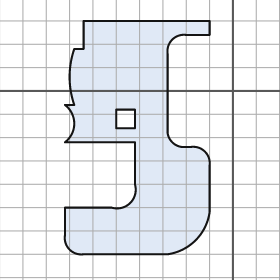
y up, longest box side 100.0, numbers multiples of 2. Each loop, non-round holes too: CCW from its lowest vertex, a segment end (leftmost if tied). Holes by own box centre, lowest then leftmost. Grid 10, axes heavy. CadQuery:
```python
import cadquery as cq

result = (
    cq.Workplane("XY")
    .moveTo(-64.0, -70.0)
    .lineTo(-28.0, -70.0)
    .threePointArc((-16.0, -64.0), (-10.0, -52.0))
    .lineTo(-10.0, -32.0)
    .threePointArc((-12.0, -26.0), (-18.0, -24.0))
    .lineTo(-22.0, -24.0)
    .threePointArc((-26.0, -22.0), (-28.0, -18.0))
    .lineTo(-28.0, 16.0)
    .threePointArc((-26.0, 22.0), (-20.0, 24.0))
    .lineTo(-10.0, 24.0)
    .lineTo(-10.0, 30.0)
    .lineTo(-64.0, 30.0)
    .lineTo(-64.0, 18.0)
    .lineTo(-68.0, 18.0)
    .threePointArc((-70.0, 6.0), (-68.0, -6.0))
    .lineTo(-72.0, -6.0)
    .threePointArc((-68.0, -14.0), (-72.0, -22.0))
    .lineTo(-42.0, -22.0)
    .lineTo(-42.0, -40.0)
    .threePointArc((-44.0, -48.0), (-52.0, -50.0))
    .lineTo(-72.0, -50.0)
    .lineTo(-72.0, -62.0)
    .threePointArc((-70.0, -68.0), (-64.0, -70.0))
    .close()
    .moveTo(-50.0, -16.0)
    .lineTo(-42.0, -16.0)
    .lineTo(-42.0, -8.0)
    .lineTo(-50.0, -8.0)
    .close()
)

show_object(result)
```